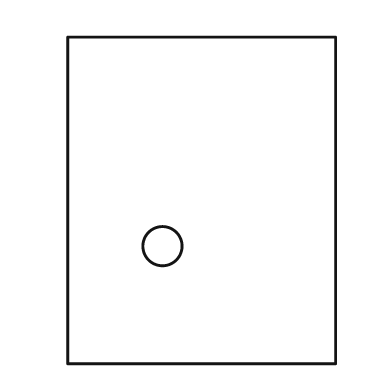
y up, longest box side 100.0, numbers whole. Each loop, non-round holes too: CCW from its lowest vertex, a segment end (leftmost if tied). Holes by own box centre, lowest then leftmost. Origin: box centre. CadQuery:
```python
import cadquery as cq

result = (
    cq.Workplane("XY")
    .moveTo(-41.0, -50.0)
    .lineTo(41.0, -50.0)
    .lineTo(41.0, 50.0)
    .lineTo(-41.0, 50.0)
    .close()
    .moveTo(-12.0, -14.0)
    .circle(6.0)
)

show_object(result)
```